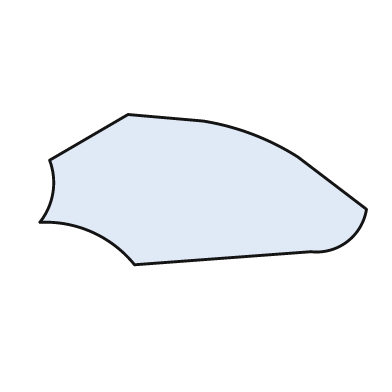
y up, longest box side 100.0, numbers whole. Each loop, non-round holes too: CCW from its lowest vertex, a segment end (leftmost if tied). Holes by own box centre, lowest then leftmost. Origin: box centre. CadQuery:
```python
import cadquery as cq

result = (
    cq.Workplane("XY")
    .moveTo(-21.0, -23.0)
    .lineTo(33.0, -19.0)
    .threePointArc((44.0, -16.0), (50.0, -6.0))
    .lineTo(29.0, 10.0)
    .threePointArc((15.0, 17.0), (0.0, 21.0))
    .lineTo(-23.0, 23.0)
    .lineTo(-47.0, 9.0)
    .threePointArc((-46.0, -1.0), (-50.0, -10.0))
    .threePointArc((-34.0, -13.0), (-21.0, -23.0))
    .close()
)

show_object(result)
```